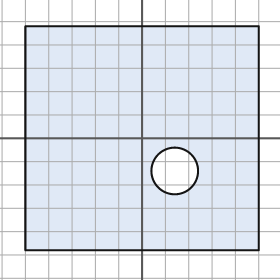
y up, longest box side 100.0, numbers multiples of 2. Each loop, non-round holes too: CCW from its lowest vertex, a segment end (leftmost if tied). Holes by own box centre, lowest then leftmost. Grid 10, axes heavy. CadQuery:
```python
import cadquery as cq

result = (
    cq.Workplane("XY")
    .moveTo(-50.0, -48.0)
    .lineTo(50.0, -48.0)
    .lineTo(50.0, 48.0)
    .lineTo(-50.0, 48.0)
    .close()
    .moveTo(14.0, -14.0)
    .circle(10.0)
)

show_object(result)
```